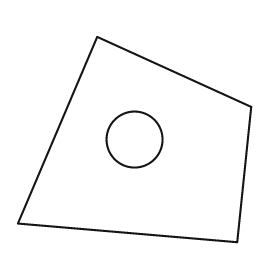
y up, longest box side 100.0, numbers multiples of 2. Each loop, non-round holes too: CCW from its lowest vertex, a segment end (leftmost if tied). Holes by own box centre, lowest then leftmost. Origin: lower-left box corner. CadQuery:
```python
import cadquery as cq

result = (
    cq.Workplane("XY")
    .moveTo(94.0, 0.0)
    .lineTo(100.0, 58.0)
    .lineTo(34.0, 88.0)
    .lineTo(0.0, 8.0)
    .close()
    .moveTo(50.0, 44.0)
    .circle(12.0)
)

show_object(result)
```